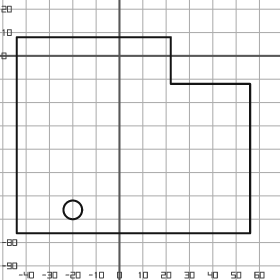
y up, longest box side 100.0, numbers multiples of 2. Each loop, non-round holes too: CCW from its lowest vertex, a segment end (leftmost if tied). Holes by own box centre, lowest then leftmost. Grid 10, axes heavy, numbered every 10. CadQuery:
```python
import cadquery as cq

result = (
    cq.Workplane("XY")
    .moveTo(-44.0, -76.0)
    .lineTo(56.0, -76.0)
    .lineTo(56.0, -12.0)
    .lineTo(22.0, -12.0)
    .lineTo(22.0, 8.0)
    .lineTo(-44.0, 8.0)
    .close()
    .moveTo(-20.0, -66.0)
    .circle(4.0)
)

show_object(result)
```